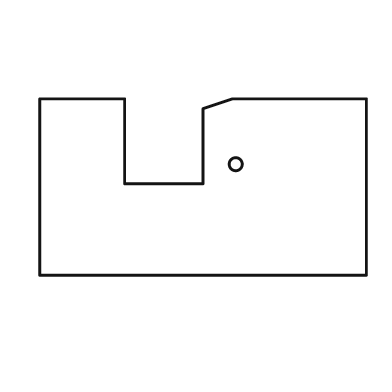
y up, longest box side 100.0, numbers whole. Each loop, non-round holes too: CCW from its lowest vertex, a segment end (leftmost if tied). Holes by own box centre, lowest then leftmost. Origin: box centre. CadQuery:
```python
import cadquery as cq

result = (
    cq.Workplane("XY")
    .moveTo(-50.0, -27.0)
    .lineTo(50.0, -27.0)
    .lineTo(50.0, 27.0)
    .lineTo(9.0, 27.0)
    .lineTo(0.0, 24.0)
    .lineTo(0.0, 1.0)
    .lineTo(-24.0, 1.0)
    .lineTo(-24.0, 27.0)
    .lineTo(-50.0, 27.0)
    .close()
    .moveTo(10.0, 7.0)
    .circle(2.0)
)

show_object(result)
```